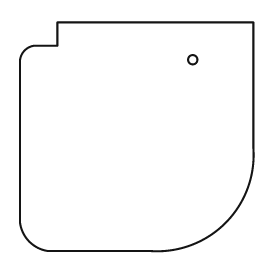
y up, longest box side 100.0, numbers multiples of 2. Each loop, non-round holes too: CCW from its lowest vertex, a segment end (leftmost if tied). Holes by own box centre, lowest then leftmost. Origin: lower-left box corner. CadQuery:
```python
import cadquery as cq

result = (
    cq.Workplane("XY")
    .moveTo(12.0, 0.0)
    .lineTo(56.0, 0.0)
    .threePointArc((88.0, 12.0), (100.0, 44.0))
    .lineTo(100.0, 98.0)
    .lineTo(16.0, 98.0)
    .lineTo(16.0, 88.0)
    .lineTo(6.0, 88.0)
    .threePointArc((2.0, 86.0), (0.0, 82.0))
    .lineTo(0.0, 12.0)
    .threePointArc((4.0, 4.0), (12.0, 0.0))
    .close()
    .moveTo(74.0, 82.0)
    .circle(2.0)
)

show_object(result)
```